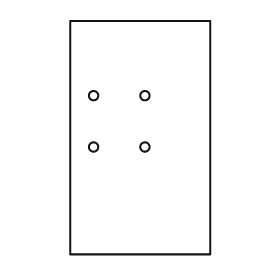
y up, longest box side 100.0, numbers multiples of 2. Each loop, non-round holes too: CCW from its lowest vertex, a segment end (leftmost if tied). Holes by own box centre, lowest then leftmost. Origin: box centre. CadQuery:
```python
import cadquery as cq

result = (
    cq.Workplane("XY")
    .moveTo(-30.0, -50.0)
    .lineTo(30.0, -50.0)
    .lineTo(30.0, 50.0)
    .lineTo(-30.0, 50.0)
    .close()
    .moveTo(-20.0, -4.0)
    .circle(2.0)
    .moveTo(2.0, -4.0)
    .circle(2.0)
    .moveTo(-20.0, 18.0)
    .circle(2.0)
    .moveTo(2.0, 18.0)
    .circle(2.0)
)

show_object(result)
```